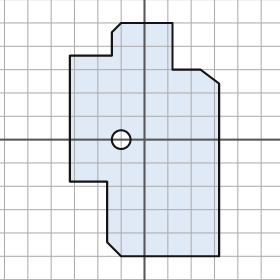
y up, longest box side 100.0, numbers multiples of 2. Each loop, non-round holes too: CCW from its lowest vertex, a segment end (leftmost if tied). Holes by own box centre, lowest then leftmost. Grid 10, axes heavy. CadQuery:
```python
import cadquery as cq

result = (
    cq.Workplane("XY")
    .moveTo(-10.0, -50.0)
    .lineTo(32.0, -50.0)
    .lineTo(32.0, 24.0)
    .lineTo(24.0, 30.0)
    .lineTo(12.0, 30.0)
    .lineTo(12.0, 50.0)
    .lineTo(-10.0, 50.0)
    .lineTo(-14.0, 46.0)
    .lineTo(-14.0, 36.0)
    .lineTo(-32.0, 36.0)
    .lineTo(-32.0, -18.0)
    .lineTo(-16.0, -18.0)
    .lineTo(-16.0, -44.0)
    .close()
    .moveTo(-10.0, 0.0)
    .circle(4.0)
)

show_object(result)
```